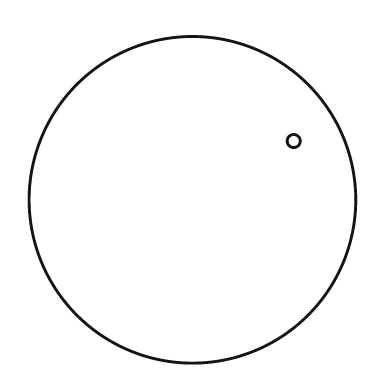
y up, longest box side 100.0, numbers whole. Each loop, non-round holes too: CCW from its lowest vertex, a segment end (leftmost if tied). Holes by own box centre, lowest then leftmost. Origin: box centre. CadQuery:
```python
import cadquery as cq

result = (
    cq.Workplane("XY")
    .moveTo(0.0, 0.0)
    .circle(50.0)
    .moveTo(31.0, 18.0)
    .circle(2.0)
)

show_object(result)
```